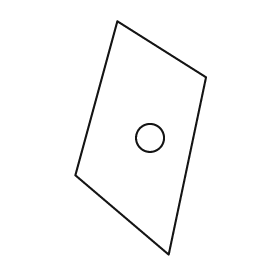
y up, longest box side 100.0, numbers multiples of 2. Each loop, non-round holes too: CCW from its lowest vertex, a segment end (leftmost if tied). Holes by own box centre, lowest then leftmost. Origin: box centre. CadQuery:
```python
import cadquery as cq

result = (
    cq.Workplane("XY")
    .moveTo(12.0, -50.0)
    .lineTo(28.0, 26.0)
    .lineTo(-10.0, 50.0)
    .lineTo(-28.0, -16.0)
    .close()
    .moveTo(4.0, 0.0)
    .circle(6.0)
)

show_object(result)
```